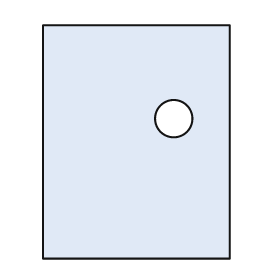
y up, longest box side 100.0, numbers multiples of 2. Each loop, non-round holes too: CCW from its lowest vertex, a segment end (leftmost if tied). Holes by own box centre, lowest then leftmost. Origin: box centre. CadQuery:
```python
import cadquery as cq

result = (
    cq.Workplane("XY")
    .moveTo(-40.0, -50.0)
    .lineTo(40.0, -50.0)
    .lineTo(40.0, 50.0)
    .lineTo(-40.0, 50.0)
    .close()
    .moveTo(16.0, 10.0)
    .circle(8.0)
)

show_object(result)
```